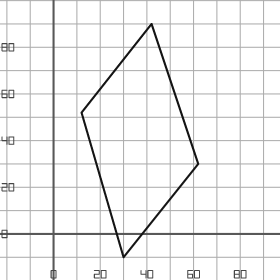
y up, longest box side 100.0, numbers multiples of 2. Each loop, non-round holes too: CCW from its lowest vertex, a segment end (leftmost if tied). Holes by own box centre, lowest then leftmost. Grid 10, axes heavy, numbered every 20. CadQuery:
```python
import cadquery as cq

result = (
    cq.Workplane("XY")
    .moveTo(30.0, -10.0)
    .lineTo(62.0, 30.0)
    .lineTo(42.0, 90.0)
    .lineTo(12.0, 52.0)
    .close()
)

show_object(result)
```